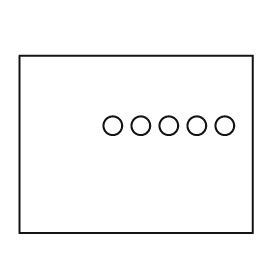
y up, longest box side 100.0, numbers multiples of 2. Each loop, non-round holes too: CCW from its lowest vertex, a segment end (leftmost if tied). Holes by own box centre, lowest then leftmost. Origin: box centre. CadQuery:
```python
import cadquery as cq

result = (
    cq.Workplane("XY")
    .moveTo(-50.0, -38.0)
    .lineTo(50.0, -38.0)
    .lineTo(50.0, 38.0)
    .lineTo(-50.0, 38.0)
    .close()
    .moveTo(-10.0, 8.0)
    .circle(4.0)
    .moveTo(2.0, 8.0)
    .circle(4.0)
    .moveTo(14.0, 8.0)
    .circle(4.0)
    .moveTo(26.0, 8.0)
    .circle(4.0)
    .moveTo(38.0, 8.0)
    .circle(4.0)
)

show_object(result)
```